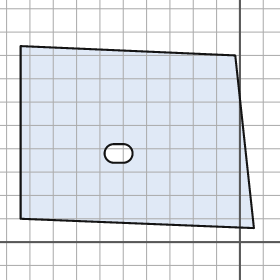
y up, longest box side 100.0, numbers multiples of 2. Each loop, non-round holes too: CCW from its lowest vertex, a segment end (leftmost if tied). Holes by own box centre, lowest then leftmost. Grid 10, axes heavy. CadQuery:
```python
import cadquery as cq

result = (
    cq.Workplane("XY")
    .moveTo(6.0, 6.0)
    .lineTo(-2.0, 80.0)
    .lineTo(-94.0, 84.0)
    .lineTo(-94.0, 10.0)
    .close()
    .moveTo(-54.0, 34.0)
    .lineTo(-50.0, 34.0)
    .threePointArc((-46.0, 38.0), (-50.0, 42.0))
    .lineTo(-54.0, 42.0)
    .threePointArc((-58.0, 38.0), (-54.0, 34.0))
    .close()
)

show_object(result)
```